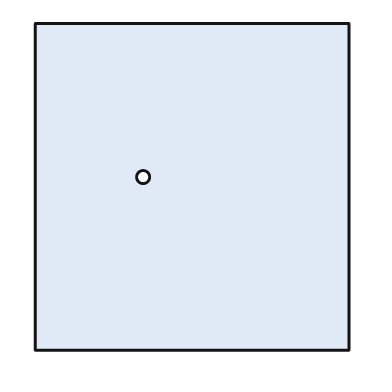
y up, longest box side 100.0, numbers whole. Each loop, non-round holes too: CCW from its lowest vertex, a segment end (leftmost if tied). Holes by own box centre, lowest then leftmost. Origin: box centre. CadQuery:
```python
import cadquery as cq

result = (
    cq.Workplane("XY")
    .moveTo(-48.0, -50.0)
    .lineTo(48.0, -50.0)
    .lineTo(48.0, 50.0)
    .lineTo(-48.0, 50.0)
    .close()
    .moveTo(-15.0, 3.0)
    .circle(2.0)
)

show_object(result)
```